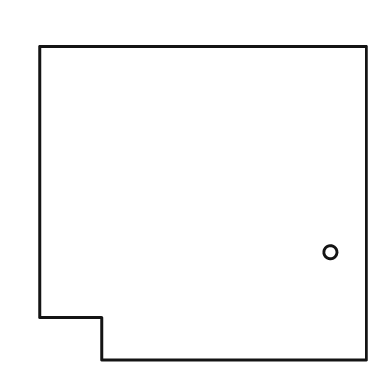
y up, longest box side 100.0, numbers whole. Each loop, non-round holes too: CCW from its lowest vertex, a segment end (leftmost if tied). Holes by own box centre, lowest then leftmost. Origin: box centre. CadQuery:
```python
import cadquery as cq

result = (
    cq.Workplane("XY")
    .moveTo(-31.0, -48.0)
    .lineTo(50.0, -48.0)
    .lineTo(50.0, 48.0)
    .lineTo(-50.0, 48.0)
    .lineTo(-50.0, -35.0)
    .lineTo(-31.0, -35.0)
    .close()
    .moveTo(39.0, -15.0)
    .circle(2.0)
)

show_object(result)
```